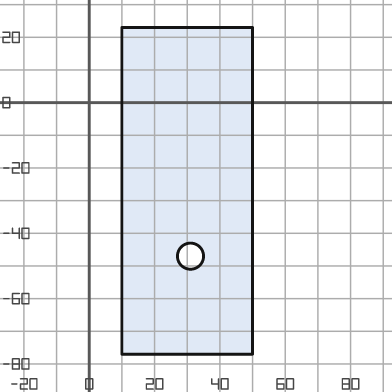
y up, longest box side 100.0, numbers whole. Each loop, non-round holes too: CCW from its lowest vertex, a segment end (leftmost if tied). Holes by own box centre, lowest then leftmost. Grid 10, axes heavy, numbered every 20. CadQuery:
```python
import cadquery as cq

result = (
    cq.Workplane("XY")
    .moveTo(10.0, -77.0)
    .lineTo(50.0, -77.0)
    .lineTo(50.0, 23.0)
    .lineTo(10.0, 23.0)
    .close()
    .moveTo(31.0, -47.0)
    .circle(4.0)
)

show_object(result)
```